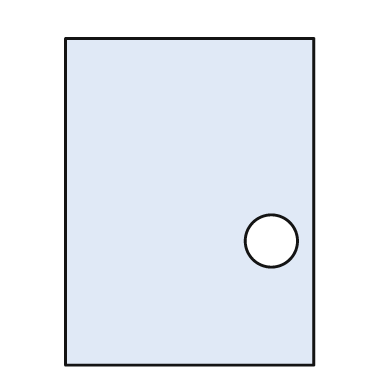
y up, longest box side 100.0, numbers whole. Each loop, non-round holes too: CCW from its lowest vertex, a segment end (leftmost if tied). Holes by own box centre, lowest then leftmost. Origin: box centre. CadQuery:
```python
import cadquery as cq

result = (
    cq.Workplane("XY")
    .moveTo(-38.0, -50.0)
    .lineTo(38.0, -50.0)
    .lineTo(38.0, 50.0)
    .lineTo(-38.0, 50.0)
    .close()
    .moveTo(25.0, -12.0)
    .circle(8.0)
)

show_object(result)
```